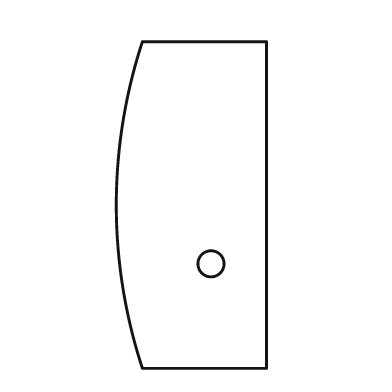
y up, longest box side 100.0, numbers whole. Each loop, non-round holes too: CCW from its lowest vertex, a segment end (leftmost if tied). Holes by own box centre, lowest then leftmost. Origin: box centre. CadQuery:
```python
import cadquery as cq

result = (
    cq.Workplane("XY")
    .moveTo(-15.0, -50.0)
    .lineTo(23.0, -50.0)
    .lineTo(23.0, 50.0)
    .lineTo(-15.0, 50.0)
    .threePointArc((-23.0, 0.0), (-15.0, -50.0))
    .close()
    .moveTo(6.0, -18.0)
    .circle(4.0)
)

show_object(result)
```